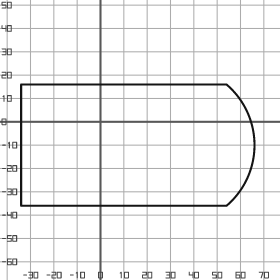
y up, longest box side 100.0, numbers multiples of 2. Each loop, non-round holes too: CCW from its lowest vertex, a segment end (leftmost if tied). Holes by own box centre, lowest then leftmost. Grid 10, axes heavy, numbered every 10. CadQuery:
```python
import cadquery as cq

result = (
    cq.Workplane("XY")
    .moveTo(-34.0, -36.0)
    .lineTo(54.0, -36.0)
    .threePointArc((66.0, -10.0), (54.0, 16.0))
    .lineTo(-34.0, 16.0)
    .close()
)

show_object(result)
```